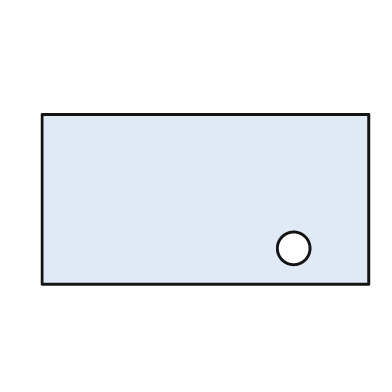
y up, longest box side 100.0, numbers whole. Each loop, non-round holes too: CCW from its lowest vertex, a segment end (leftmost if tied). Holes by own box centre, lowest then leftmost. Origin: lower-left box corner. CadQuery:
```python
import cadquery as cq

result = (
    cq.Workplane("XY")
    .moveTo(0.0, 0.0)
    .lineTo(100.0, 0.0)
    .lineTo(100.0, 52.0)
    .lineTo(0.0, 52.0)
    .close()
    .moveTo(77.0, 11.0)
    .circle(5.0)
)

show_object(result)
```